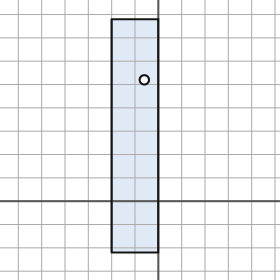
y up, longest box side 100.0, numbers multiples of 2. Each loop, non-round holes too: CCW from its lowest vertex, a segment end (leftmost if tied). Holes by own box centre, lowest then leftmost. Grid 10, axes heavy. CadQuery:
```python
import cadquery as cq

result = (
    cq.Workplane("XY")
    .moveTo(-20.0, -22.0)
    .lineTo(0.0, -22.0)
    .lineTo(0.0, 78.0)
    .lineTo(-20.0, 78.0)
    .close()
    .moveTo(-6.0, 52.0)
    .circle(2.0)
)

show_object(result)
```